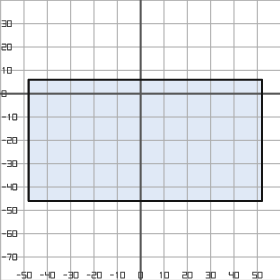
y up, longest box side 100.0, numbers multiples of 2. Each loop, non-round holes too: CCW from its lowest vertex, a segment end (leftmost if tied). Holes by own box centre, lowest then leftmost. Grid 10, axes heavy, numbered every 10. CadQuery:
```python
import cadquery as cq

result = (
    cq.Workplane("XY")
    .moveTo(-48.0, -46.0)
    .lineTo(52.0, -46.0)
    .lineTo(52.0, 6.0)
    .lineTo(-48.0, 6.0)
    .close()
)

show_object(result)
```